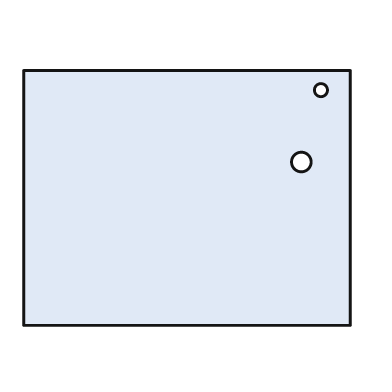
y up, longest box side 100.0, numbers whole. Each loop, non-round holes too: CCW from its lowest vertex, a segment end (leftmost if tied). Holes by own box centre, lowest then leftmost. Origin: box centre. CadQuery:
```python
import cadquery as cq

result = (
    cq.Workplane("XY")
    .moveTo(-50.0, -39.0)
    .lineTo(50.0, -39.0)
    .lineTo(50.0, 39.0)
    .lineTo(-50.0, 39.0)
    .close()
    .moveTo(35.0, 11.0)
    .circle(3.0)
    .moveTo(41.0, 33.0)
    .circle(2.0)
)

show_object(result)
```